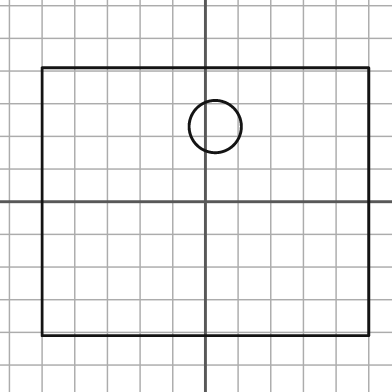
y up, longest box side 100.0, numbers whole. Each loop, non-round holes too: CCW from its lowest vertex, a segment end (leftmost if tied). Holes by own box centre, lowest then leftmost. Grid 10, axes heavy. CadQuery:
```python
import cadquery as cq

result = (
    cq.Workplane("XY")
    .moveTo(-50.0, -41.0)
    .lineTo(50.0, -41.0)
    .lineTo(50.0, 41.0)
    .lineTo(-50.0, 41.0)
    .close()
    .moveTo(3.0, 23.0)
    .circle(8.0)
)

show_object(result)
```